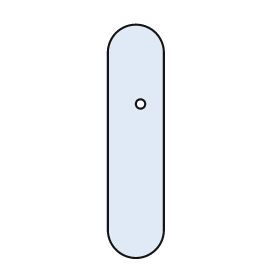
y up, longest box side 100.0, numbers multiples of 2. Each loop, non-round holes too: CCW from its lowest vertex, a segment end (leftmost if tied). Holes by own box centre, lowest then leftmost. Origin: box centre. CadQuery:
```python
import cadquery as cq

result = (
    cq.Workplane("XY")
    .moveTo(-12.0, -38.0)
    .threePointArc((0.0, -50.0), (12.0, -38.0))
    .lineTo(12.0, 38.0)
    .threePointArc((0.0, 50.0), (-12.0, 38.0))
    .close()
    .moveTo(2.0, 16.0)
    .circle(2.0)
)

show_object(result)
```